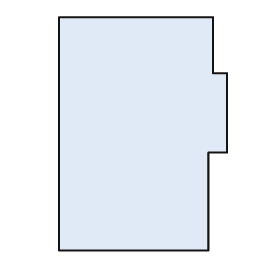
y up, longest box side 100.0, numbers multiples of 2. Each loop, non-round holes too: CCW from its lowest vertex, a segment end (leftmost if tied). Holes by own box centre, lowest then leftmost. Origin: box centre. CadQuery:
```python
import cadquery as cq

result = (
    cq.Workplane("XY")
    .moveTo(-36.0, -50.0)
    .lineTo(28.0, -50.0)
    .lineTo(28.0, -8.0)
    .lineTo(36.0, -8.0)
    .lineTo(36.0, 26.0)
    .lineTo(30.0, 26.0)
    .lineTo(30.0, 50.0)
    .lineTo(-36.0, 50.0)
    .close()
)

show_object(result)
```